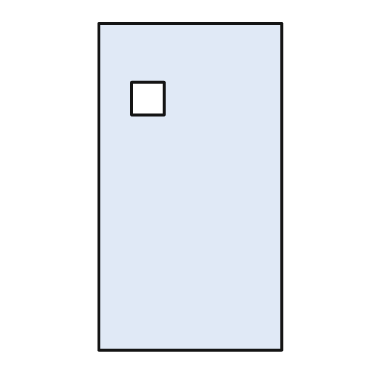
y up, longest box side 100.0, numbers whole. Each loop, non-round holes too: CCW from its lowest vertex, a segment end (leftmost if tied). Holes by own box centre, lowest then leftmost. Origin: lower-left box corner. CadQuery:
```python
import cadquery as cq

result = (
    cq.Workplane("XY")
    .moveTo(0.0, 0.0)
    .lineTo(56.0, 0.0)
    .lineTo(56.0, 100.0)
    .lineTo(0.0, 100.0)
    .close()
    .moveTo(10.0, 72.0)
    .lineTo(20.0, 72.0)
    .lineTo(20.0, 82.0)
    .lineTo(10.0, 82.0)
    .close()
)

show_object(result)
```